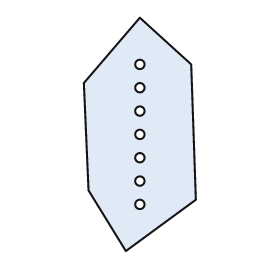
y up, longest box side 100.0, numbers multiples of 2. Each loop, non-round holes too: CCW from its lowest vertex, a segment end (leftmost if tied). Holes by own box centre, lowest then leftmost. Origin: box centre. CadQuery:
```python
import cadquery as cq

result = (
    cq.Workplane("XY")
    .moveTo(-6.0, -50.0)
    .lineTo(24.0, -28.0)
    .lineTo(22.0, 30.0)
    .lineTo(0.0, 50.0)
    .lineTo(-24.0, 22.0)
    .lineTo(-22.0, -24.0)
    .close()
    .moveTo(0.0, -30.0)
    .circle(2.0)
    .moveTo(0.0, -20.0)
    .circle(2.0)
    .moveTo(0.0, -10.0)
    .circle(2.0)
    .moveTo(0.0, 0.0)
    .circle(2.0)
    .moveTo(0.0, 10.0)
    .circle(2.0)
    .moveTo(0.0, 20.0)
    .circle(2.0)
    .moveTo(0.0, 30.0)
    .circle(2.0)
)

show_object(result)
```